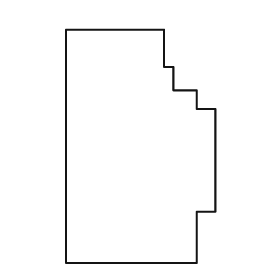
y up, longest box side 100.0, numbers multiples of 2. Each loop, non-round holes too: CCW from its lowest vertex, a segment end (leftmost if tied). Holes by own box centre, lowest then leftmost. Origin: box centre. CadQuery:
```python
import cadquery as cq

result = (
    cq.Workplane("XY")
    .moveTo(-32.0, -50.0)
    .lineTo(24.0, -50.0)
    .lineTo(24.0, -28.0)
    .lineTo(32.0, -28.0)
    .lineTo(32.0, 16.0)
    .lineTo(24.0, 16.0)
    .lineTo(24.0, 24.0)
    .lineTo(14.0, 24.0)
    .lineTo(14.0, 34.0)
    .lineTo(10.0, 34.0)
    .lineTo(10.0, 50.0)
    .lineTo(-32.0, 50.0)
    .close()
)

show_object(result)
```